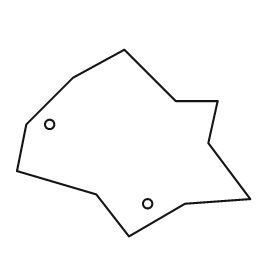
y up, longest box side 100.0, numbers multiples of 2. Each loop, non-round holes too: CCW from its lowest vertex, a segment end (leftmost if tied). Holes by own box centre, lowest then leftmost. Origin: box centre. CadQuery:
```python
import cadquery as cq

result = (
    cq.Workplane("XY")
    .moveTo(-2.0, -40.0)
    .lineTo(22.0, -26.0)
    .lineTo(50.0, -24.0)
    .lineTo(32.0, 0.0)
    .lineTo(36.0, 18.0)
    .lineTo(18.0, 18.0)
    .lineTo(-4.0, 40.0)
    .lineTo(-26.0, 28.0)
    .lineTo(-46.0, 8.0)
    .lineTo(-50.0, -12.0)
    .lineTo(-16.0, -22.0)
    .close()
    .moveTo(6.0, -26.0)
    .circle(2.0)
    .moveTo(-36.0, 8.0)
    .circle(2.0)
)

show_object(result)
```